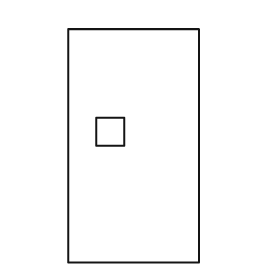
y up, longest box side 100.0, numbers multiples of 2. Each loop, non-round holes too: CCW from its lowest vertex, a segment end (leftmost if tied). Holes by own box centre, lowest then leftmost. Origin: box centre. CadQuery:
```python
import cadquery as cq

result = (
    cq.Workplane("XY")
    .moveTo(-28.0, -50.0)
    .lineTo(28.0, -50.0)
    .lineTo(28.0, 50.0)
    .lineTo(-28.0, 50.0)
    .close()
    .moveTo(-16.0, 0.0)
    .lineTo(-4.0, 0.0)
    .lineTo(-4.0, 12.0)
    .lineTo(-16.0, 12.0)
    .close()
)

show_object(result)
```